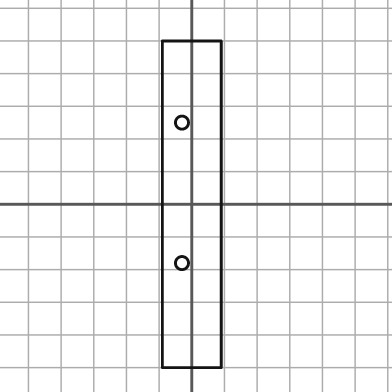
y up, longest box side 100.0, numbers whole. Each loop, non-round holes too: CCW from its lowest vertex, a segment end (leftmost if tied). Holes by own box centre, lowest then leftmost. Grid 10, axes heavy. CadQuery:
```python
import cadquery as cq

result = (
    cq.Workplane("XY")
    .moveTo(-9.0, -50.0)
    .lineTo(9.0, -50.0)
    .lineTo(9.0, 50.0)
    .lineTo(-9.0, 50.0)
    .close()
    .moveTo(-3.0, -18.0)
    .circle(2.0)
    .moveTo(-3.0, 25.0)
    .circle(2.0)
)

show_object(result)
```